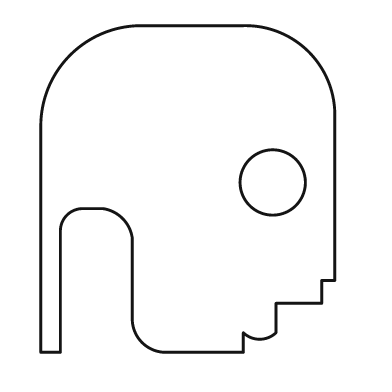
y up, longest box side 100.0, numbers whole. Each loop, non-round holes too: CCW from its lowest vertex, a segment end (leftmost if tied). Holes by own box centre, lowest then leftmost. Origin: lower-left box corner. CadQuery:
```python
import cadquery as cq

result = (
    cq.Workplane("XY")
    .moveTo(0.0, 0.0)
    .lineTo(6.0, 0.0)
    .lineTo(6.0, 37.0)
    .threePointArc((8.0, 42.0), (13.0, 44.0))
    .lineTo(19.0, 44.0)
    .threePointArc((25.0, 41.0), (28.0, 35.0))
    .lineTo(28.0, 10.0)
    .threePointArc((31.0, 3.0), (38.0, 0.0))
    .lineTo(62.0, 0.0)
    .lineTo(62.0, 6.0)
    .threePointArc((67.0, 4.0), (72.0, 6.0))
    .lineTo(72.0, 15.0)
    .lineTo(86.0, 15.0)
    .lineTo(86.0, 22.0)
    .lineTo(90.0, 22.0)
    .lineTo(90.0, 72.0)
    .threePointArc((82.0, 92.0), (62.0, 100.0))
    .lineTo(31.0, 100.0)
    .threePointArc((9.0, 91.0), (0.0, 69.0))
    .close()
    .moveTo(71.0, 52.0)
    .circle(10.0)
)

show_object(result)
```